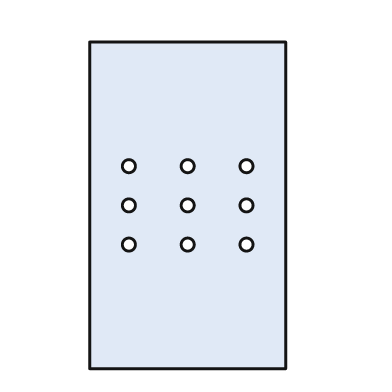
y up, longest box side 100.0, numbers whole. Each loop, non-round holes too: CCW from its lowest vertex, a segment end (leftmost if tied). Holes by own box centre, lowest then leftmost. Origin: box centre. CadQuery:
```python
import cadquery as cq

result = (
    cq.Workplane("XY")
    .moveTo(-30.0, -50.0)
    .lineTo(30.0, -50.0)
    .lineTo(30.0, 50.0)
    .lineTo(-30.0, 50.0)
    .close()
    .moveTo(-18.0, -12.0)
    .circle(2.0)
    .moveTo(0.0, -12.0)
    .circle(2.0)
    .moveTo(18.0, -12.0)
    .circle(2.0)
    .moveTo(-18.0, 0.0)
    .circle(2.0)
    .moveTo(0.0, 0.0)
    .circle(2.0)
    .moveTo(18.0, 0.0)
    .circle(2.0)
    .moveTo(-18.0, 12.0)
    .circle(2.0)
    .moveTo(0.0, 12.0)
    .circle(2.0)
    .moveTo(18.0, 12.0)
    .circle(2.0)
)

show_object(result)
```